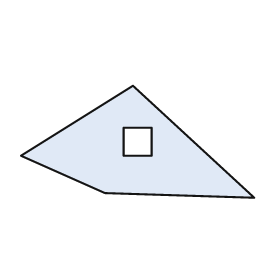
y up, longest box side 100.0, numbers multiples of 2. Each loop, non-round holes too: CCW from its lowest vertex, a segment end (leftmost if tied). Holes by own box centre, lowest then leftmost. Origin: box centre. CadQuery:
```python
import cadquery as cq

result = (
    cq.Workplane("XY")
    .moveTo(50.0, -24.0)
    .lineTo(-2.0, 24.0)
    .lineTo(-50.0, -6.0)
    .lineTo(-14.0, -22.0)
    .close()
    .moveTo(-6.0, -6.0)
    .lineTo(6.0, -6.0)
    .lineTo(6.0, 6.0)
    .lineTo(-6.0, 6.0)
    .close()
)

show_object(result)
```